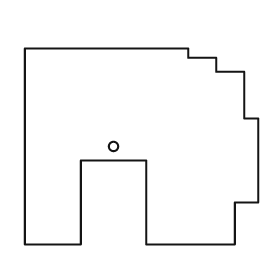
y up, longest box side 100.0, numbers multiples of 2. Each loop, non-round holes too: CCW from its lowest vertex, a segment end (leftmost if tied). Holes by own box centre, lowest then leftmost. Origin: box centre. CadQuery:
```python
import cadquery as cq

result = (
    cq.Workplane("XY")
    .moveTo(-50.0, -42.0)
    .lineTo(-26.0, -42.0)
    .lineTo(-26.0, -6.0)
    .lineTo(2.0, -6.0)
    .lineTo(2.0, -42.0)
    .lineTo(40.0, -42.0)
    .lineTo(40.0, -24.0)
    .lineTo(50.0, -24.0)
    .lineTo(50.0, 12.0)
    .lineTo(44.0, 12.0)
    .lineTo(44.0, 32.0)
    .lineTo(32.0, 32.0)
    .lineTo(32.0, 38.0)
    .lineTo(20.0, 38.0)
    .lineTo(20.0, 42.0)
    .lineTo(-50.0, 42.0)
    .close()
    .moveTo(-12.0, 0.0)
    .circle(2.0)
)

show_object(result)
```